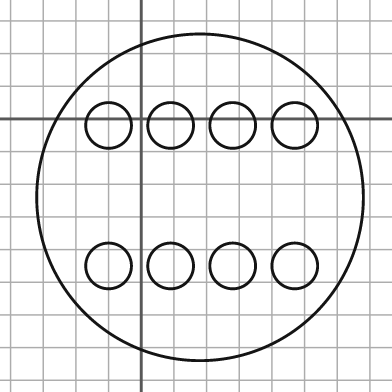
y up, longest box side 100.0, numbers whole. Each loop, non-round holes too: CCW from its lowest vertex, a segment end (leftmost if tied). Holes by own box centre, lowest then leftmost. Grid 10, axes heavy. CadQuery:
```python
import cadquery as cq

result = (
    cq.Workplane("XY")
    .moveTo(18.0, -24.0)
    .circle(50.0)
    .moveTo(-10.0, -45.0)
    .circle(7.0)
    .moveTo(9.0, -45.0)
    .circle(7.0)
    .moveTo(28.0, -45.0)
    .circle(7.0)
    .moveTo(47.0, -45.0)
    .circle(7.0)
    .moveTo(-10.0, -2.0)
    .circle(7.0)
    .moveTo(9.0, -2.0)
    .circle(7.0)
    .moveTo(28.0, -2.0)
    .circle(7.0)
    .moveTo(47.0, -2.0)
    .circle(7.0)
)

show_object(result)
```